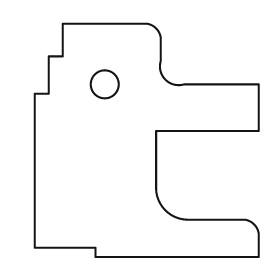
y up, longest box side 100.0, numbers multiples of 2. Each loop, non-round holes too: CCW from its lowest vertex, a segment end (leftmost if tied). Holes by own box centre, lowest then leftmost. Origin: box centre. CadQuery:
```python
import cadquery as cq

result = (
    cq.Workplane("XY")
    .moveTo(-22.0, -50.0)
    .lineTo(48.0, -50.0)
    .lineTo(48.0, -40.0)
    .threePointArc((46.0, -36.0), (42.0, -34.0))
    .lineTo(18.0, -34.0)
    .threePointArc((8.0, -30.0), (4.0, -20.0))
    .lineTo(4.0, 4.0)
    .lineTo(48.0, 4.0)
    .lineTo(48.0, 24.0)
    .lineTo(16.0, 24.0)
    .threePointArc((8.0, 26.0), (6.0, 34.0))
    .lineTo(6.0, 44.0)
    .threePointArc((4.0, 48.0), (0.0, 50.0))
    .lineTo(-36.0, 50.0)
    .lineTo(-36.0, 36.0)
    .lineTo(-42.0, 36.0)
    .lineTo(-42.0, 20.0)
    .lineTo(-48.0, 20.0)
    .lineTo(-48.0, -46.0)
    .lineTo(-22.0, -46.0)
    .close()
    .moveTo(-18.0, 24.0)
    .circle(6.0)
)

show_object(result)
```